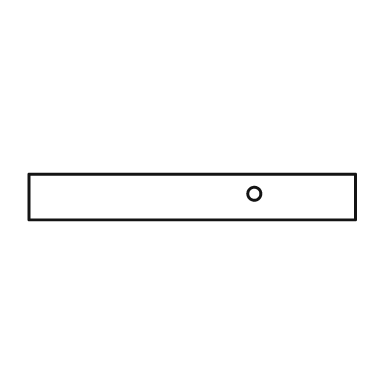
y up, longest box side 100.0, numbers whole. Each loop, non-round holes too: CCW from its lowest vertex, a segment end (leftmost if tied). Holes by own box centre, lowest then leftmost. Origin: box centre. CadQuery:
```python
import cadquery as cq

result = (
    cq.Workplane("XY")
    .moveTo(-50.0, -7.0)
    .lineTo(50.0, -7.0)
    .lineTo(50.0, 7.0)
    .lineTo(-50.0, 7.0)
    .close()
    .moveTo(19.0, 1.0)
    .circle(2.0)
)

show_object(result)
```